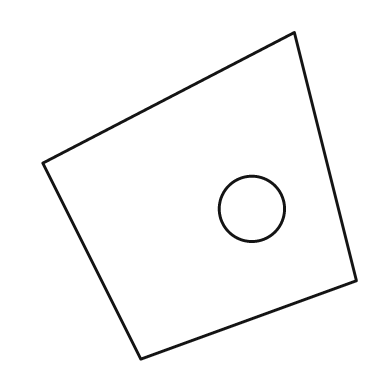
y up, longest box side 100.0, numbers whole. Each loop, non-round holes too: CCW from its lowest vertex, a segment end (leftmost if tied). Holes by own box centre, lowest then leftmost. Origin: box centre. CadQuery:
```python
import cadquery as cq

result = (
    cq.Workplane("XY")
    .moveTo(-18.0, -50.0)
    .lineTo(48.0, -26.0)
    .lineTo(29.0, 50.0)
    .lineTo(-48.0, 10.0)
    .close()
    .moveTo(16.0, -4.0)
    .circle(10.0)
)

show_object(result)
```